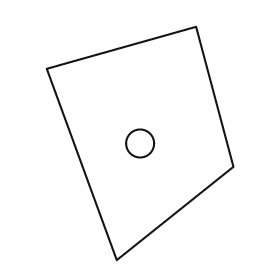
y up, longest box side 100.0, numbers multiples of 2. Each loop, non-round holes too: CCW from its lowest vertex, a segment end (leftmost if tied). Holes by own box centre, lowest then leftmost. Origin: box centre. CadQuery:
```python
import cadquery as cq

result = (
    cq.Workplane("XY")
    .moveTo(-10.0, -50.0)
    .lineTo(40.0, -10.0)
    .lineTo(24.0, 50.0)
    .lineTo(-40.0, 32.0)
    .close()
    .moveTo(0.0, 0.0)
    .circle(6.0)
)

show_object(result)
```